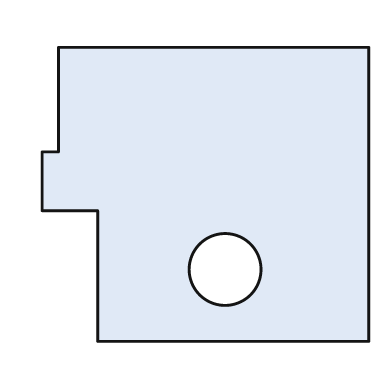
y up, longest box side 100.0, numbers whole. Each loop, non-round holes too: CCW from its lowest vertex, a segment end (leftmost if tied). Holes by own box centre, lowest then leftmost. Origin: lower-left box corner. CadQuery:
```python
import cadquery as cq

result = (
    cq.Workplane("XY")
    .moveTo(17.0, 0.0)
    .lineTo(100.0, 0.0)
    .lineTo(100.0, 90.0)
    .lineTo(5.0, 90.0)
    .lineTo(5.0, 58.0)
    .lineTo(0.0, 58.0)
    .lineTo(0.0, 40.0)
    .lineTo(17.0, 40.0)
    .close()
    .moveTo(56.0, 22.0)
    .circle(11.0)
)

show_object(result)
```